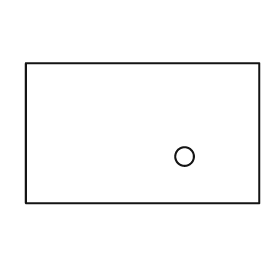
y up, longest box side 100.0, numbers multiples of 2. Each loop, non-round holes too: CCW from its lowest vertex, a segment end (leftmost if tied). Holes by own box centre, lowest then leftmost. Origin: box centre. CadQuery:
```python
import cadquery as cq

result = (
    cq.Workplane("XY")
    .moveTo(-50.0, -30.0)
    .lineTo(50.0, -30.0)
    .lineTo(50.0, 30.0)
    .lineTo(-50.0, 30.0)
    .close()
    .moveTo(18.0, -10.0)
    .circle(4.0)
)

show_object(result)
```